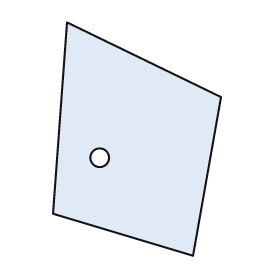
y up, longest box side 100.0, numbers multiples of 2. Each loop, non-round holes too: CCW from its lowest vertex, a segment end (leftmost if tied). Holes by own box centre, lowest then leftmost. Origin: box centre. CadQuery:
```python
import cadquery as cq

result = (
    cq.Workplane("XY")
    .moveTo(24.0, -50.0)
    .lineTo(36.0, 18.0)
    .lineTo(-30.0, 50.0)
    .lineTo(-36.0, -32.0)
    .close()
    .moveTo(-16.0, -8.0)
    .circle(4.0)
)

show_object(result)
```